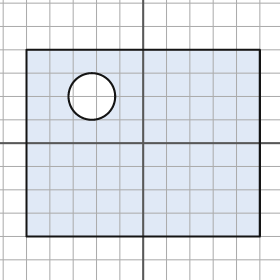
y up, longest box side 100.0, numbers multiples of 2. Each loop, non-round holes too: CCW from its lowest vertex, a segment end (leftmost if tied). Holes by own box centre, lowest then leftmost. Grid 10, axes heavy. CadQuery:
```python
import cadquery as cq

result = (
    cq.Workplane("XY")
    .moveTo(-50.0, -40.0)
    .lineTo(50.0, -40.0)
    .lineTo(50.0, 40.0)
    .lineTo(-50.0, 40.0)
    .close()
    .moveTo(-22.0, 20.0)
    .circle(10.0)
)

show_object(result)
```